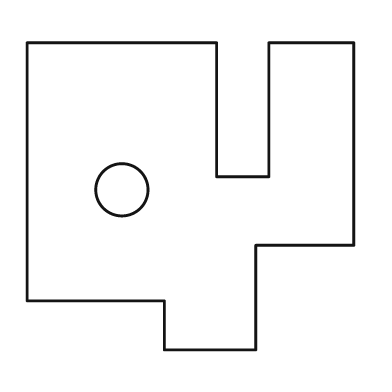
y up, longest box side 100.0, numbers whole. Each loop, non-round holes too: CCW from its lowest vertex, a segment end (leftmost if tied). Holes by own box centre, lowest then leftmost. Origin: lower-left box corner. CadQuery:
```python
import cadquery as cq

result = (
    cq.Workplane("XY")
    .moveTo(42.0, 0.0)
    .lineTo(70.0, 0.0)
    .lineTo(70.0, 32.0)
    .lineTo(100.0, 32.0)
    .lineTo(100.0, 94.0)
    .lineTo(74.0, 94.0)
    .lineTo(74.0, 53.0)
    .lineTo(58.0, 53.0)
    .lineTo(58.0, 94.0)
    .lineTo(0.0, 94.0)
    .lineTo(0.0, 15.0)
    .lineTo(42.0, 15.0)
    .close()
    .moveTo(29.0, 49.0)
    .circle(8.0)
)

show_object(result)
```